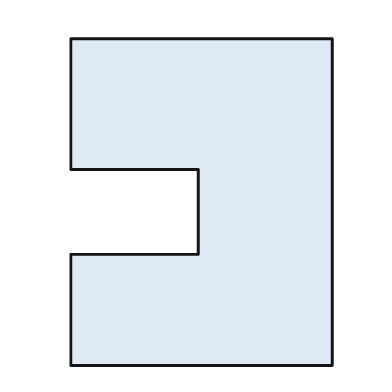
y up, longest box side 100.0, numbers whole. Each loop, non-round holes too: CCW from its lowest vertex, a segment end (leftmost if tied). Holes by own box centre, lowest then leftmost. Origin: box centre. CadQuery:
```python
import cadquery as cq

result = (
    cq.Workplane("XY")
    .moveTo(-40.0, -50.0)
    .lineTo(40.0, -50.0)
    .lineTo(40.0, 50.0)
    .lineTo(-40.0, 50.0)
    .lineTo(-40.0, 10.0)
    .lineTo(-1.0, 10.0)
    .lineTo(-1.0, -16.0)
    .lineTo(-40.0, -16.0)
    .close()
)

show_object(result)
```